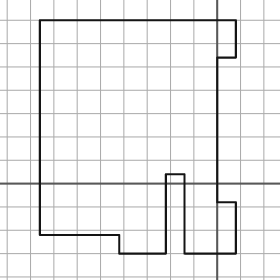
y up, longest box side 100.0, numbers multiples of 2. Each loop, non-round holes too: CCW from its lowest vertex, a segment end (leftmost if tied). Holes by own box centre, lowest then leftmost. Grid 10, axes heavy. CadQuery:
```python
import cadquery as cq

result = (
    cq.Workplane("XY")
    .moveTo(-42.0, -30.0)
    .lineTo(-22.0, -30.0)
    .lineTo(-22.0, 4.0)
    .lineTo(-14.0, 4.0)
    .lineTo(-14.0, -30.0)
    .lineTo(8.0, -30.0)
    .lineTo(8.0, -8.0)
    .lineTo(0.0, -8.0)
    .lineTo(0.0, 54.0)
    .lineTo(8.0, 54.0)
    .lineTo(8.0, 70.0)
    .lineTo(-76.0, 70.0)
    .lineTo(-76.0, -22.0)
    .lineTo(-42.0, -22.0)
    .close()
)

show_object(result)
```